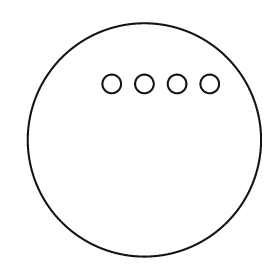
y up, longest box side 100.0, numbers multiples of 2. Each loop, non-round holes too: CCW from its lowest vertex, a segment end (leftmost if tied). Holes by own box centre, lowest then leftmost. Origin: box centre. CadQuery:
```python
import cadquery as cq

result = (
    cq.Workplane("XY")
    .moveTo(0.0, 0.0)
    .circle(50.0)
    .moveTo(-14.0, 24.0)
    .circle(4.0)
    .moveTo(0.0, 24.0)
    .circle(4.0)
    .moveTo(14.0, 24.0)
    .circle(4.0)
    .moveTo(28.0, 24.0)
    .circle(4.0)
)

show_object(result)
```